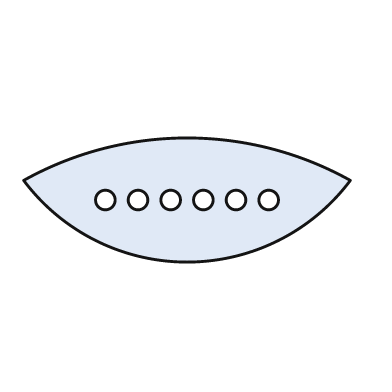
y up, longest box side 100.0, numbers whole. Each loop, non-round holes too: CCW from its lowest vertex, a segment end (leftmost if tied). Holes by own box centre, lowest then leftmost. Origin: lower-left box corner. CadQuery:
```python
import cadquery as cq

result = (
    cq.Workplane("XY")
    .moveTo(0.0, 25.0)
    .threePointArc((50.0, 0.0), (100.0, 25.0))
    .threePointArc((50.0, 38.0), (0.0, 25.0))
    .close()
    .moveTo(25.0, 19.0)
    .circle(3.0)
    .moveTo(35.0, 19.0)
    .circle(3.0)
    .moveTo(45.0, 19.0)
    .circle(3.0)
    .moveTo(55.0, 19.0)
    .circle(3.0)
    .moveTo(65.0, 19.0)
    .circle(3.0)
    .moveTo(75.0, 19.0)
    .circle(3.0)
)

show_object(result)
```